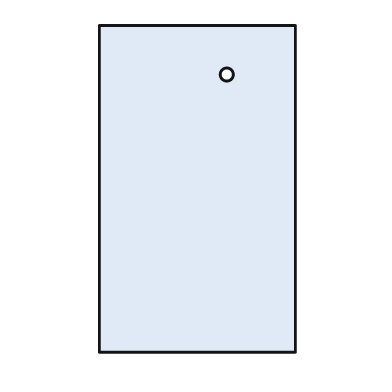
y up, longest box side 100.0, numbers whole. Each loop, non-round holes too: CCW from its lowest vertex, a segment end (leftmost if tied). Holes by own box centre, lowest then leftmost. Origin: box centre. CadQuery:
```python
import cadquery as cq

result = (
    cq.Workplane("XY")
    .moveTo(-30.0, -50.0)
    .lineTo(30.0, -50.0)
    .lineTo(30.0, 50.0)
    .lineTo(-30.0, 50.0)
    .close()
    .moveTo(9.0, 35.0)
    .circle(2.0)
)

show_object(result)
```